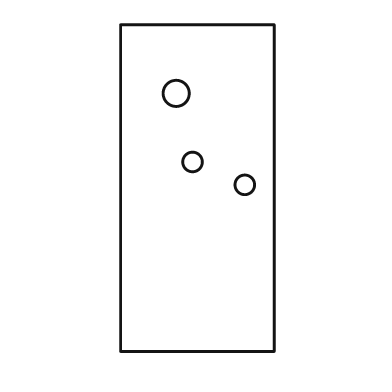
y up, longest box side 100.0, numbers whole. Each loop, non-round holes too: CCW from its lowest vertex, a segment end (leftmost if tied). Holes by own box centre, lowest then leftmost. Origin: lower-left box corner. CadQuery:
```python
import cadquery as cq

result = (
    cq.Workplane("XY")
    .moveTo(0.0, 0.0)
    .lineTo(47.0, 0.0)
    .lineTo(47.0, 100.0)
    .lineTo(0.0, 100.0)
    .close()
    .moveTo(38.0, 51.0)
    .circle(3.0)
    .moveTo(22.0, 58.0)
    .circle(3.0)
    .moveTo(17.0, 79.0)
    .circle(4.0)
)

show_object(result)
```